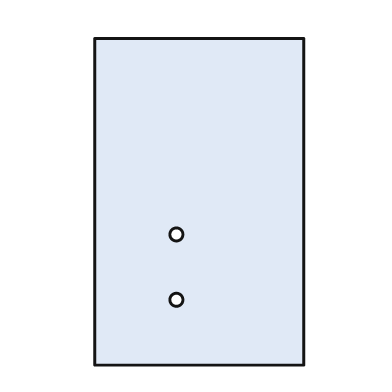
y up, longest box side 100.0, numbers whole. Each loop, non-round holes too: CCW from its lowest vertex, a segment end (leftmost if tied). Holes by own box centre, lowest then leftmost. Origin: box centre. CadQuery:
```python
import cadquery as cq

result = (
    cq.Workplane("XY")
    .moveTo(-32.0, -50.0)
    .lineTo(32.0, -50.0)
    .lineTo(32.0, 50.0)
    .lineTo(-32.0, 50.0)
    .close()
    .moveTo(-7.0, -30.0)
    .circle(2.0)
    .moveTo(-7.0, -10.0)
    .circle(2.0)
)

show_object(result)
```